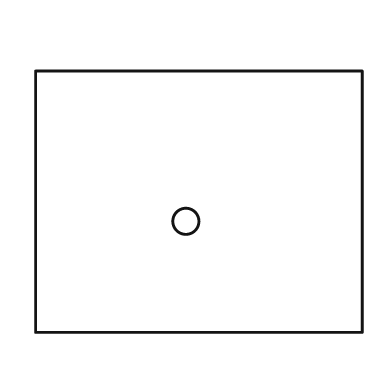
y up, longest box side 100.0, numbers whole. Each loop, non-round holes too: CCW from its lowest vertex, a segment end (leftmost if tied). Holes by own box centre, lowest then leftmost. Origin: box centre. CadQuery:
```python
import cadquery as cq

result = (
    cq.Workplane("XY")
    .moveTo(-50.0, -40.0)
    .lineTo(50.0, -40.0)
    .lineTo(50.0, 40.0)
    .lineTo(-50.0, 40.0)
    .close()
    .moveTo(-4.0, -6.0)
    .circle(4.0)
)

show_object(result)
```